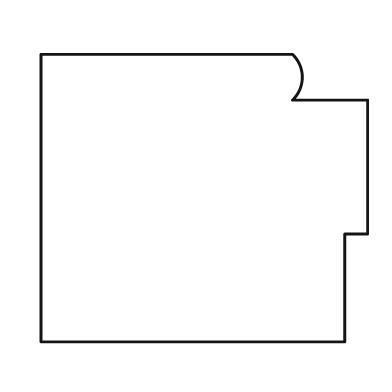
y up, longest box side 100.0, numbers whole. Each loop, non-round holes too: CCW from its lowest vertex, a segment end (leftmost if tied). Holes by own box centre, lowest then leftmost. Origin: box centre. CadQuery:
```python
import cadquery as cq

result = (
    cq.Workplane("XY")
    .moveTo(-50.0, -44.0)
    .lineTo(43.0, -44.0)
    .lineTo(43.0, -11.0)
    .lineTo(50.0, -11.0)
    .lineTo(50.0, 30.0)
    .lineTo(27.0, 30.0)
    .threePointArc((30.0, 37.0), (27.0, 44.0))
    .lineTo(-50.0, 44.0)
    .close()
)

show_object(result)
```